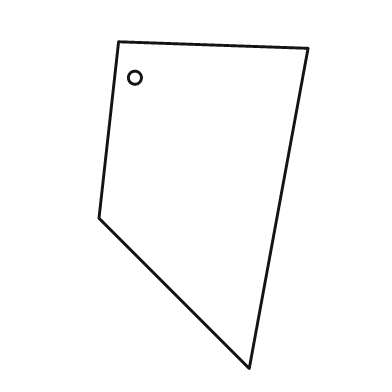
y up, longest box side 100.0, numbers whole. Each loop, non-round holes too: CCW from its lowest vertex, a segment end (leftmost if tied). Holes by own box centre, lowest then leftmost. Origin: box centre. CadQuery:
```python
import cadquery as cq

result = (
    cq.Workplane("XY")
    .moveTo(14.0, -50.0)
    .lineTo(32.0, 48.0)
    .lineTo(-26.0, 50.0)
    .lineTo(-32.0, -4.0)
    .close()
    .moveTo(-21.0, 39.0)
    .circle(2.0)
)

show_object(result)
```